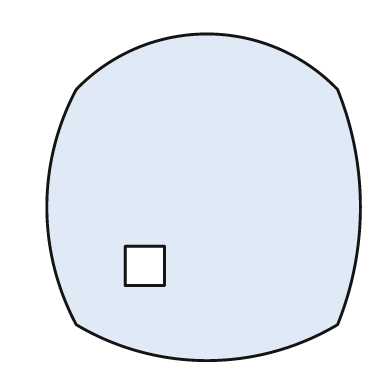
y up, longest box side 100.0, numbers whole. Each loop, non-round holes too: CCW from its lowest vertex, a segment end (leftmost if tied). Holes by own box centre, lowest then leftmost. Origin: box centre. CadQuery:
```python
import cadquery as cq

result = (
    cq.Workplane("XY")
    .moveTo(-39.0, -39.0)
    .threePointArc((1.0, -50.0), (41.0, -39.0))
    .threePointArc((48.0, -3.0), (41.0, 33.0))
    .threePointArc((1.0, 50.0), (-39.0, 33.0))
    .threePointArc((-48.0, -3.0), (-39.0, -39.0))
    .close()
    .moveTo(-24.0, -27.0)
    .lineTo(-12.0, -27.0)
    .lineTo(-12.0, -15.0)
    .lineTo(-24.0, -15.0)
    .close()
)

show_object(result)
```